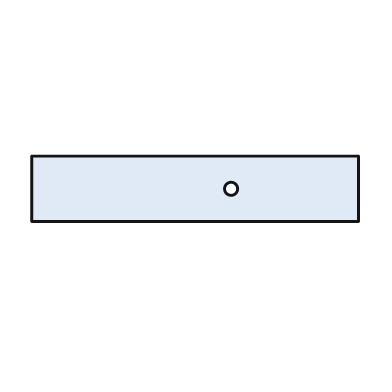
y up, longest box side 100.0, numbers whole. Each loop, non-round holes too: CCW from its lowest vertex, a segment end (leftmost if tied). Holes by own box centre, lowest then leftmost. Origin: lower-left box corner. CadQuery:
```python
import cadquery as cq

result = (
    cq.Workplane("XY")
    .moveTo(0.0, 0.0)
    .lineTo(100.0, 0.0)
    .lineTo(100.0, 20.0)
    .lineTo(0.0, 20.0)
    .close()
    .moveTo(61.0, 10.0)
    .circle(2.0)
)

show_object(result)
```